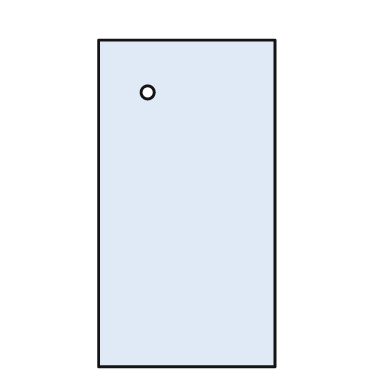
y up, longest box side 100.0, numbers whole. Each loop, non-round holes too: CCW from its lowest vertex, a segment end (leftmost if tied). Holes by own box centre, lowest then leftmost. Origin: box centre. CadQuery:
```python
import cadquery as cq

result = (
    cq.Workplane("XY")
    .moveTo(-27.0, -50.0)
    .lineTo(27.0, -50.0)
    .lineTo(27.0, 50.0)
    .lineTo(-27.0, 50.0)
    .close()
    .moveTo(-12.0, 34.0)
    .circle(2.0)
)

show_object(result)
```